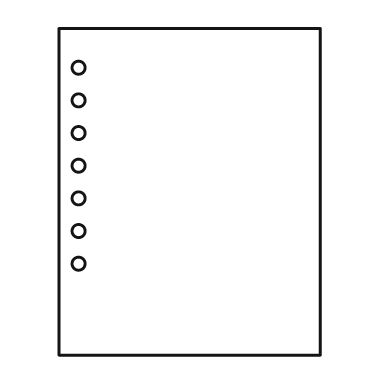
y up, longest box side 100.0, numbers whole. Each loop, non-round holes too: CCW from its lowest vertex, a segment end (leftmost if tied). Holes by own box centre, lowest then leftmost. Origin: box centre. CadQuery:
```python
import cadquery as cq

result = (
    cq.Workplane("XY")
    .moveTo(-40.0, -50.0)
    .lineTo(40.0, -50.0)
    .lineTo(40.0, 50.0)
    .lineTo(-40.0, 50.0)
    .close()
    .moveTo(-34.0, -22.0)
    .circle(2.0)
    .moveTo(-34.0, -12.0)
    .circle(2.0)
    .moveTo(-34.0, -2.0)
    .circle(2.0)
    .moveTo(-34.0, 8.0)
    .circle(2.0)
    .moveTo(-34.0, 18.0)
    .circle(2.0)
    .moveTo(-34.0, 28.0)
    .circle(2.0)
    .moveTo(-34.0, 38.0)
    .circle(2.0)
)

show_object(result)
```